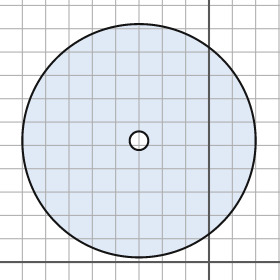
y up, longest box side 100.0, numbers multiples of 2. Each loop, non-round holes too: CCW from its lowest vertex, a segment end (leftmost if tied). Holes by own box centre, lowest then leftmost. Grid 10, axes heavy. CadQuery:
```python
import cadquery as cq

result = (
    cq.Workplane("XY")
    .moveTo(-30.0, 52.0)
    .circle(50.0)
    .moveTo(-30.0, 52.0)
    .circle(4.0)
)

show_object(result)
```